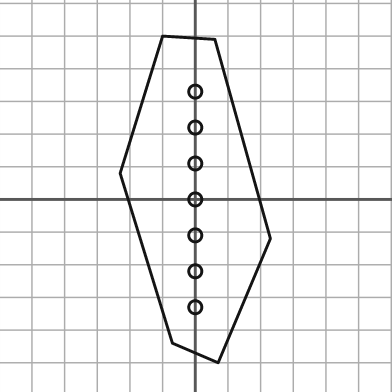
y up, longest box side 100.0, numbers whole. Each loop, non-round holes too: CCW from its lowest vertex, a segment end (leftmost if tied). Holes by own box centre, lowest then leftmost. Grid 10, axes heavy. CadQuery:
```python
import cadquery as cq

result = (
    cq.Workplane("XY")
    .moveTo(7.0, -50.0)
    .lineTo(23.0, -12.0)
    .lineTo(6.0, 49.0)
    .lineTo(-10.0, 50.0)
    .lineTo(-23.0, 8.0)
    .lineTo(-7.0, -44.0)
    .close()
    .moveTo(0.0, -33.0)
    .circle(2.0)
    .moveTo(0.0, -22.0)
    .circle(2.0)
    .moveTo(0.0, -11.0)
    .circle(2.0)
    .moveTo(0.0, 0.0)
    .circle(2.0)
    .moveTo(0.0, 11.0)
    .circle(2.0)
    .moveTo(0.0, 22.0)
    .circle(2.0)
    .moveTo(0.0, 33.0)
    .circle(2.0)
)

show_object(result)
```